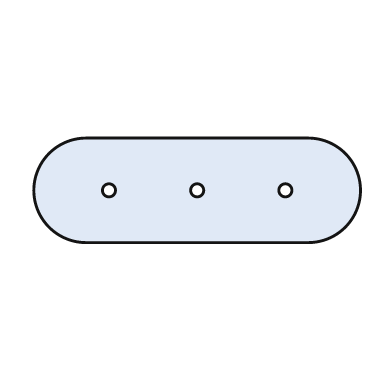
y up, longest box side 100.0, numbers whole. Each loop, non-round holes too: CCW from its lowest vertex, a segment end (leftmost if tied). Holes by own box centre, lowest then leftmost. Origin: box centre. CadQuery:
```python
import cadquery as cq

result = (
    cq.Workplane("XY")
    .moveTo(-34.0, -16.0)
    .lineTo(34.0, -16.0)
    .threePointArc((50.0, 0.0), (34.0, 16.0))
    .lineTo(-34.0, 16.0)
    .threePointArc((-50.0, 0.0), (-34.0, -16.0))
    .close()
    .moveTo(-27.0, 0.0)
    .circle(2.0)
    .moveTo(0.0, 0.0)
    .circle(2.0)
    .moveTo(27.0, 0.0)
    .circle(2.0)
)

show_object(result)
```